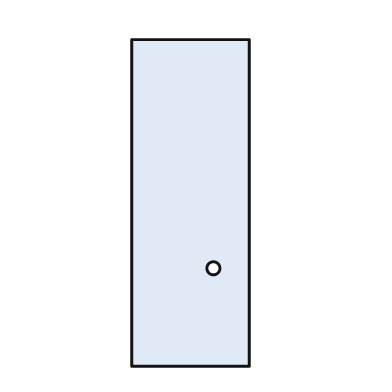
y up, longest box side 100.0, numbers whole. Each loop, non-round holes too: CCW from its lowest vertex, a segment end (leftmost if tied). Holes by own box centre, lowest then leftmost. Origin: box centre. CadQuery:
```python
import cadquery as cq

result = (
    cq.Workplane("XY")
    .moveTo(-18.0, -50.0)
    .lineTo(18.0, -50.0)
    .lineTo(18.0, 50.0)
    .lineTo(-18.0, 50.0)
    .close()
    .moveTo(7.0, -20.0)
    .circle(2.0)
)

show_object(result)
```